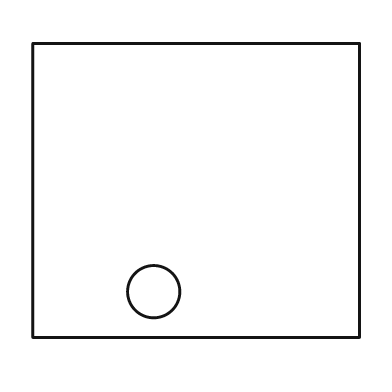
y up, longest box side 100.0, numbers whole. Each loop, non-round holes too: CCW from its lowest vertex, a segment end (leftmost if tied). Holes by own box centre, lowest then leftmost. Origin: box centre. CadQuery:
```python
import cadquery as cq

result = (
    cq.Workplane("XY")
    .moveTo(-50.0, -45.0)
    .lineTo(50.0, -45.0)
    .lineTo(50.0, 45.0)
    .lineTo(-50.0, 45.0)
    .close()
    .moveTo(-13.0, -31.0)
    .circle(8.0)
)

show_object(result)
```